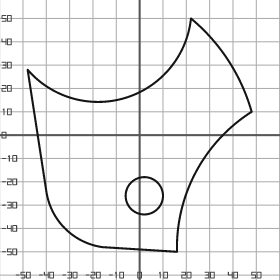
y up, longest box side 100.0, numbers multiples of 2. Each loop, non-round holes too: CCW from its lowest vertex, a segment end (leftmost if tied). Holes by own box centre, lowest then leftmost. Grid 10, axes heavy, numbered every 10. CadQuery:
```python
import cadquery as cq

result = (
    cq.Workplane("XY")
    .moveTo(16.0, -50.0)
    .threePointArc((24.0, -16.0), (48.0, 10.0))
    .threePointArc((38.0, 32.0), (22.0, 50.0))
    .threePointArc((-6.0, 16.0), (-48.0, 28.0))
    .lineTo(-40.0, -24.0)
    .threePointArc((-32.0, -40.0), (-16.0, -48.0))
    .close()
    .moveTo(2.0, -26.0)
    .circle(8.0)
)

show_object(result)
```